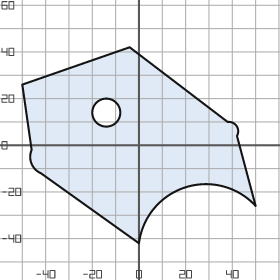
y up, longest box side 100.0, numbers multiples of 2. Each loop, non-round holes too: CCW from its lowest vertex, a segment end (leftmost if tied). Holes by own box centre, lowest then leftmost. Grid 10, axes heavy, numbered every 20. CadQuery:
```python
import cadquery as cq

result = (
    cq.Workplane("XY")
    .moveTo(0.0, -42.0)
    .threePointArc((20.0, -18.0), (50.0, -26.0))
    .lineTo(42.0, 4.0)
    .threePointArc((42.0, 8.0), (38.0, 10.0))
    .lineTo(-4.0, 42.0)
    .lineTo(-50.0, 26.0)
    .lineTo(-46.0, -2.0)
    .threePointArc((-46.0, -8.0), (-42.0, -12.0))
    .close()
    .moveTo(-14.0, 14.0)
    .circle(6.0)
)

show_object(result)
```